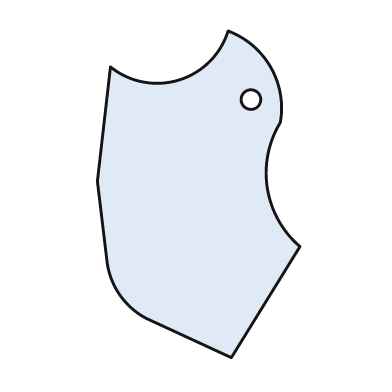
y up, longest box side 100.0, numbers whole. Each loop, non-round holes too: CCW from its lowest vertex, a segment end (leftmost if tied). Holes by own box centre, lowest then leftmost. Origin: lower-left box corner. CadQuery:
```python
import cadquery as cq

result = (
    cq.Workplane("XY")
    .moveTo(41.0, 0.0)
    .lineTo(62.0, 34.0)
    .threePointArc((52.0, 52.0), (56.0, 72.0))
    .threePointArc((53.0, 89.0), (40.0, 100.0))
    .threePointArc((25.0, 85.0), (4.0, 89.0))
    .lineTo(0.0, 54.0)
    .lineTo(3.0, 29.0)
    .threePointArc((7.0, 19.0), (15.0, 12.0))
    .close()
    .moveTo(47.0, 79.0)
    .circle(3.0)
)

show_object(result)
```